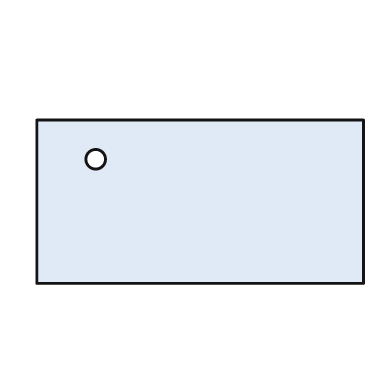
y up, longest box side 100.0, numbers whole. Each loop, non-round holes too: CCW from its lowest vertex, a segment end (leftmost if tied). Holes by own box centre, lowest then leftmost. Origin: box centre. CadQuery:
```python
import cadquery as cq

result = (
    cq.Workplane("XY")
    .moveTo(-50.0, -25.0)
    .lineTo(50.0, -25.0)
    .lineTo(50.0, 25.0)
    .lineTo(-50.0, 25.0)
    .close()
    .moveTo(-32.0, 13.0)
    .circle(3.0)
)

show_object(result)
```